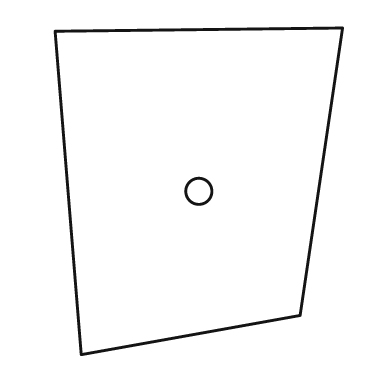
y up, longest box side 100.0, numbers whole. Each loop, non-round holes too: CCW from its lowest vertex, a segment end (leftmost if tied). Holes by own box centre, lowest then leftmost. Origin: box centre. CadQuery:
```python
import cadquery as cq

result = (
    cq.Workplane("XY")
    .moveTo(-36.0, -50.0)
    .lineTo(31.0, -38.0)
    .lineTo(44.0, 50.0)
    .lineTo(-44.0, 49.0)
    .close()
    .moveTo(0.0, 0.0)
    .circle(4.0)
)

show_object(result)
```